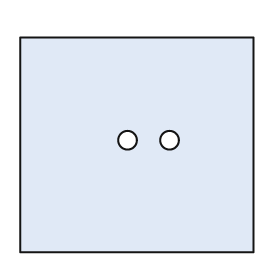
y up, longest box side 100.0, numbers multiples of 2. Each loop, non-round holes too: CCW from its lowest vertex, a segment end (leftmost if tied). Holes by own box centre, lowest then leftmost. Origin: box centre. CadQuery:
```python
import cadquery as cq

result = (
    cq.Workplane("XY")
    .moveTo(-50.0, -46.0)
    .lineTo(50.0, -46.0)
    .lineTo(50.0, 46.0)
    .lineTo(-50.0, 46.0)
    .close()
    .moveTo(-4.0, 2.0)
    .circle(4.0)
    .moveTo(14.0, 2.0)
    .circle(4.0)
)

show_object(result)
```